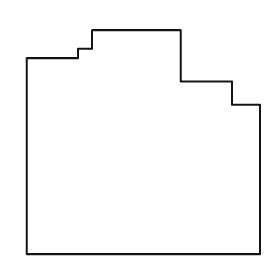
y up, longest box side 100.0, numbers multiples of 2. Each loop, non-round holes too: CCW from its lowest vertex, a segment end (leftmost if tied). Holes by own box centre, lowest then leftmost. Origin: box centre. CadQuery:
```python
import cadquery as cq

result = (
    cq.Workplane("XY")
    .moveTo(-50.0, -48.0)
    .lineTo(50.0, -48.0)
    .lineTo(50.0, 16.0)
    .lineTo(38.0, 16.0)
    .lineTo(38.0, 26.0)
    .lineTo(16.0, 26.0)
    .lineTo(16.0, 48.0)
    .lineTo(-22.0, 48.0)
    .lineTo(-22.0, 40.0)
    .lineTo(-28.0, 40.0)
    .lineTo(-28.0, 36.0)
    .lineTo(-50.0, 36.0)
    .close()
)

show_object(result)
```